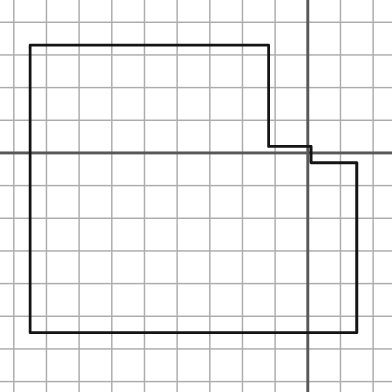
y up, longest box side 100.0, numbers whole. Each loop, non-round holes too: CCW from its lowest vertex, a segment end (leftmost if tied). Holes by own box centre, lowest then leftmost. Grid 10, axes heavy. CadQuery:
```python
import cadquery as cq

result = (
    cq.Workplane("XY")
    .moveTo(-85.0, -55.0)
    .lineTo(15.0, -55.0)
    .lineTo(15.0, -3.0)
    .lineTo(1.0, -3.0)
    .lineTo(1.0, 2.0)
    .lineTo(-12.0, 2.0)
    .lineTo(-12.0, 33.0)
    .lineTo(-85.0, 33.0)
    .close()
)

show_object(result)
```